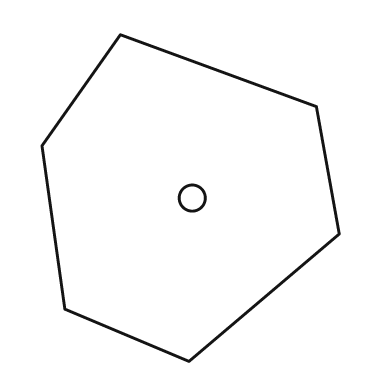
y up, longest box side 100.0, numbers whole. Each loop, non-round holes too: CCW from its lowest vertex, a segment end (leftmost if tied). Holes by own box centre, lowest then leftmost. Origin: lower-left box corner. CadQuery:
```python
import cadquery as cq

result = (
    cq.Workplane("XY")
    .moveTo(45.0, 0.0)
    .lineTo(91.0, 39.0)
    .lineTo(84.0, 78.0)
    .lineTo(24.0, 100.0)
    .lineTo(0.0, 66.0)
    .lineTo(7.0, 16.0)
    .close()
    .moveTo(46.0, 50.0)
    .circle(4.0)
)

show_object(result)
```